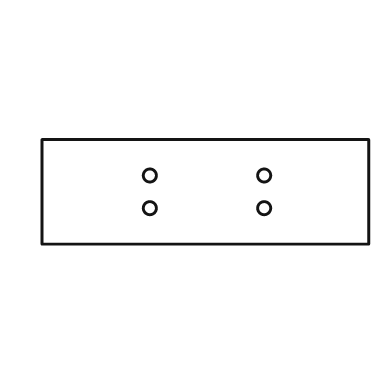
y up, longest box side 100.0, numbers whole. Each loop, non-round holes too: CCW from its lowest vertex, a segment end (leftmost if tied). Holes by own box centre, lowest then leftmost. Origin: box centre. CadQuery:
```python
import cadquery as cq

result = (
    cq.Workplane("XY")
    .moveTo(-50.0, -16.0)
    .lineTo(50.0, -16.0)
    .lineTo(50.0, 16.0)
    .lineTo(-50.0, 16.0)
    .close()
    .moveTo(-17.0, -5.0)
    .circle(2.0)
    .moveTo(18.0, -5.0)
    .circle(2.0)
    .moveTo(-17.0, 5.0)
    .circle(2.0)
    .moveTo(18.0, 5.0)
    .circle(2.0)
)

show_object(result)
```